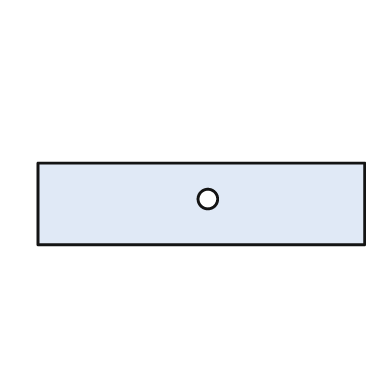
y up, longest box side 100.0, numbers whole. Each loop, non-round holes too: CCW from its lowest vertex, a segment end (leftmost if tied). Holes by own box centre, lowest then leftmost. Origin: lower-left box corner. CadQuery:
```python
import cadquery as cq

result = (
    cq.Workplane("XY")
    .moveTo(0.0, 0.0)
    .lineTo(100.0, 0.0)
    .lineTo(100.0, 25.0)
    .lineTo(0.0, 25.0)
    .close()
    .moveTo(52.0, 14.0)
    .circle(3.0)
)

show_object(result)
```